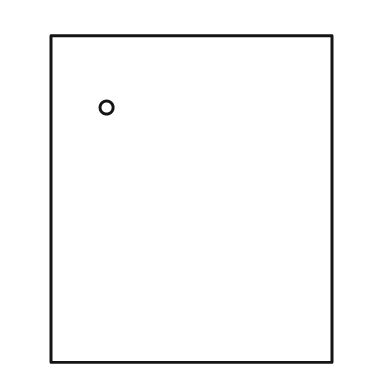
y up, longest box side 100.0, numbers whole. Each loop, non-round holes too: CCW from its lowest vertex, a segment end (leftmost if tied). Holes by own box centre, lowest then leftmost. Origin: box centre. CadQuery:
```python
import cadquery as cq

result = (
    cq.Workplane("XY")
    .moveTo(-43.0, -50.0)
    .lineTo(43.0, -50.0)
    .lineTo(43.0, 50.0)
    .lineTo(-43.0, 50.0)
    .close()
    .moveTo(-26.0, 28.0)
    .circle(2.0)
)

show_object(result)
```